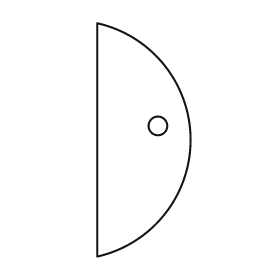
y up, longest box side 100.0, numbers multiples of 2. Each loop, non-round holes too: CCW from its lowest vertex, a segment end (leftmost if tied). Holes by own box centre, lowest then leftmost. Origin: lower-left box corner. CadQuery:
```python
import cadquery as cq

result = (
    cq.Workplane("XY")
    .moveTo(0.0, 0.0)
    .threePointArc((40.0, 50.0), (0.0, 100.0))
    .close()
    .moveTo(26.0, 56.0)
    .circle(4.0)
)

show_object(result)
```